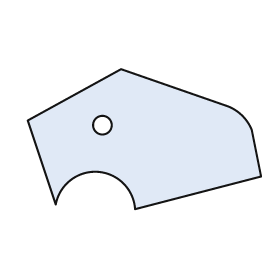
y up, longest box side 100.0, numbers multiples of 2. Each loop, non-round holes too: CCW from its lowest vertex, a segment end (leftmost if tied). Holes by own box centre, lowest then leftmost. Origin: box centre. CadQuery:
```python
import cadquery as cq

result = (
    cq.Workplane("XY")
    .moveTo(-4.0, -30.0)
    .lineTo(50.0, -16.0)
    .lineTo(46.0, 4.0)
    .threePointArc((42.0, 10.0), (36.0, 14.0))
    .lineTo(-10.0, 30.0)
    .lineTo(-50.0, 8.0)
    .lineTo(-38.0, -28.0)
    .threePointArc((-20.0, -14.0), (-4.0, -30.0))
    .close()
    .moveTo(-18.0, 6.0)
    .circle(4.0)
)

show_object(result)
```